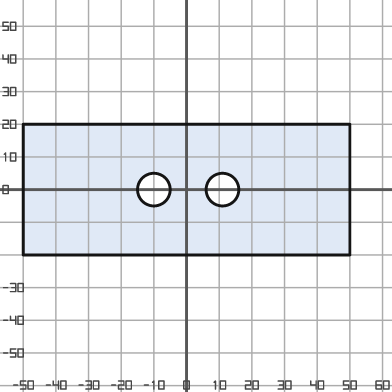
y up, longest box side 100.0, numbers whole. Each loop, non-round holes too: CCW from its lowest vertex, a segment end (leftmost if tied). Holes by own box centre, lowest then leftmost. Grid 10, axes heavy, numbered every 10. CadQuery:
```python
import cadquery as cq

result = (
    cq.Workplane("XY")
    .moveTo(-50.0, -20.0)
    .lineTo(50.0, -20.0)
    .lineTo(50.0, 20.0)
    .lineTo(-50.0, 20.0)
    .close()
    .moveTo(-10.0, 0.0)
    .circle(5.0)
    .moveTo(11.0, 0.0)
    .circle(5.0)
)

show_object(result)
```